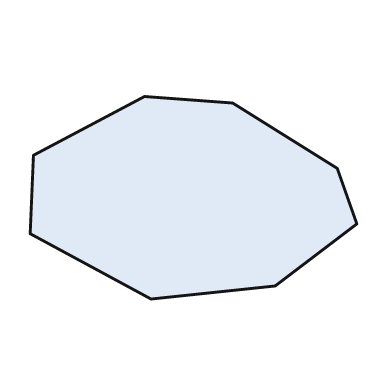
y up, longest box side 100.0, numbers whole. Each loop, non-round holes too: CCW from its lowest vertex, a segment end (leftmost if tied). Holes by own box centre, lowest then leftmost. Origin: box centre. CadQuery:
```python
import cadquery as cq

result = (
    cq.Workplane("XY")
    .moveTo(-13.0, -31.0)
    .lineTo(25.0, -27.0)
    .lineTo(50.0, -8.0)
    .lineTo(44.0, 9.0)
    .lineTo(12.0, 29.0)
    .lineTo(-15.0, 31.0)
    .lineTo(-49.0, 13.0)
    .lineTo(-50.0, -11.0)
    .close()
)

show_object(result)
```